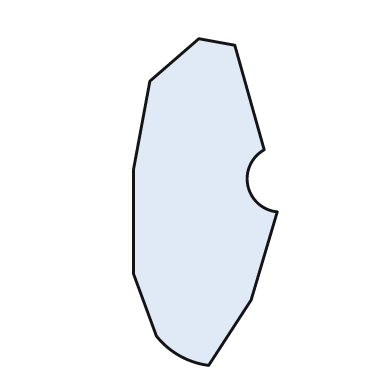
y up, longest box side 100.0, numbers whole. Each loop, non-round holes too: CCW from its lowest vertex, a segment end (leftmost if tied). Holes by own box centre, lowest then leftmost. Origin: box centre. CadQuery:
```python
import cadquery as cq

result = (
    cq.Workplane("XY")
    .moveTo(1.0, -50.0)
    .lineTo(14.0, -30.0)
    .lineTo(22.0, -3.0)
    .threePointArc((13.0, 5.0), (18.0, 16.0))
    .lineTo(9.0, 48.0)
    .lineTo(-2.0, 50.0)
    .lineTo(-17.0, 37.0)
    .lineTo(-22.0, 10.0)
    .lineTo(-22.0, -22.0)
    .lineTo(-15.0, -41.0)
    .threePointArc((-8.0, -47.0), (1.0, -50.0))
    .close()
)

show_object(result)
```